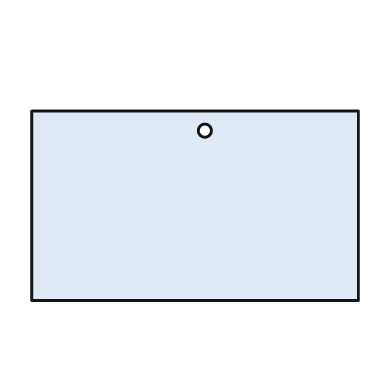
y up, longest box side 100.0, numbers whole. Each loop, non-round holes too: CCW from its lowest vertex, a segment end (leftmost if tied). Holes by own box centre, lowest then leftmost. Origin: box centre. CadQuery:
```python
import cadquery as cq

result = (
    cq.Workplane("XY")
    .moveTo(-50.0, -29.0)
    .lineTo(50.0, -29.0)
    .lineTo(50.0, 29.0)
    .lineTo(-50.0, 29.0)
    .close()
    .moveTo(3.0, 23.0)
    .circle(2.0)
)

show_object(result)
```